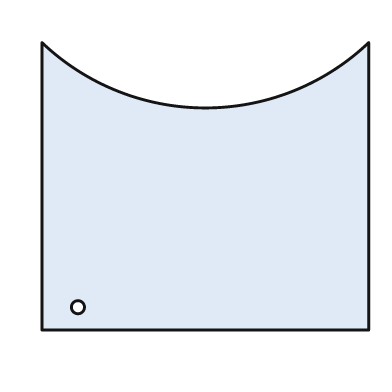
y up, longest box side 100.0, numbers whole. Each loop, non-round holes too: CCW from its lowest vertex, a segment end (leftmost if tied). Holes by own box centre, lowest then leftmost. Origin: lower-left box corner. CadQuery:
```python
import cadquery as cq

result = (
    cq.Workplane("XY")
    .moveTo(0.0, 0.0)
    .lineTo(100.0, 0.0)
    .lineTo(100.0, 88.0)
    .threePointArc((50.0, 68.0), (0.0, 88.0))
    .close()
    .moveTo(11.0, 7.0)
    .circle(2.0)
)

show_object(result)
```